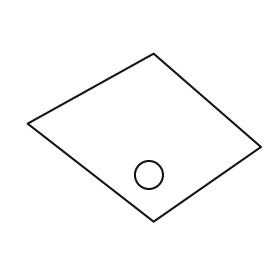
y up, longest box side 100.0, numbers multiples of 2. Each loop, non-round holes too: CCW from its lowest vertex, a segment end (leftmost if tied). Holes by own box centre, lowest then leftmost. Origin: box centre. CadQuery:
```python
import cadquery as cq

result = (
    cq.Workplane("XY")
    .moveTo(4.0, -36.0)
    .lineTo(50.0, -4.0)
    .lineTo(4.0, 36.0)
    .lineTo(-50.0, 6.0)
    .close()
    .moveTo(2.0, -16.0)
    .circle(6.0)
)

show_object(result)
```